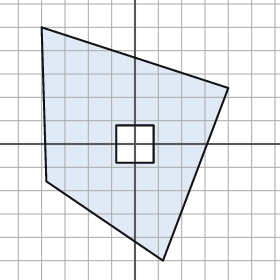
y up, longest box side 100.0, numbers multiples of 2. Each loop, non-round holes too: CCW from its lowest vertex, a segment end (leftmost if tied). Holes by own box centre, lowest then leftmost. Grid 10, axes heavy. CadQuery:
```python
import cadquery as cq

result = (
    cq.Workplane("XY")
    .moveTo(12.0, -50.0)
    .lineTo(40.0, 24.0)
    .lineTo(-40.0, 50.0)
    .lineTo(-38.0, -16.0)
    .close()
    .moveTo(-8.0, -8.0)
    .lineTo(8.0, -8.0)
    .lineTo(8.0, 8.0)
    .lineTo(-8.0, 8.0)
    .close()
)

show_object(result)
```